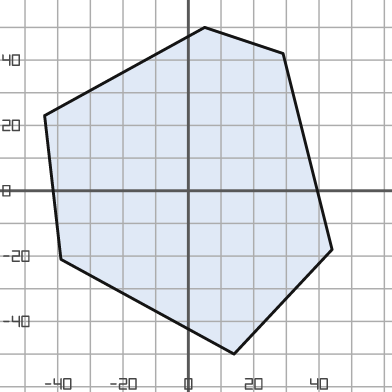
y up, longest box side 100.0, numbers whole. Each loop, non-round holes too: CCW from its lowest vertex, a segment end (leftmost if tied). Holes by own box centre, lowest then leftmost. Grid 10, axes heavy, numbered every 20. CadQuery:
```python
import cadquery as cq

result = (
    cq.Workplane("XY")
    .moveTo(14.0, -50.0)
    .lineTo(44.0, -18.0)
    .lineTo(29.0, 42.0)
    .lineTo(5.0, 50.0)
    .lineTo(-44.0, 23.0)
    .lineTo(-39.0, -21.0)
    .close()
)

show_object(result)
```